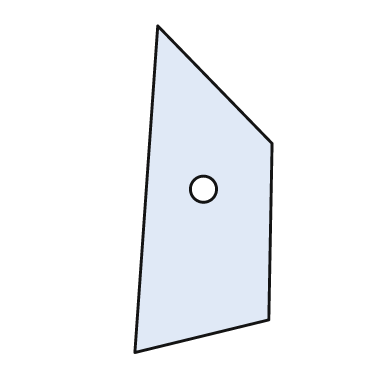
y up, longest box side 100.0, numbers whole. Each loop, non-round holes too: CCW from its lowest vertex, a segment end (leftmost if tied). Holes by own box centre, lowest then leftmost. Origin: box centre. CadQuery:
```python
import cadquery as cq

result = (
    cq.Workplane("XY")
    .moveTo(-21.0, -50.0)
    .lineTo(20.0, -40.0)
    .lineTo(21.0, 14.0)
    .lineTo(-14.0, 50.0)
    .close()
    .moveTo(0.0, 0.0)
    .circle(4.0)
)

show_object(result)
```